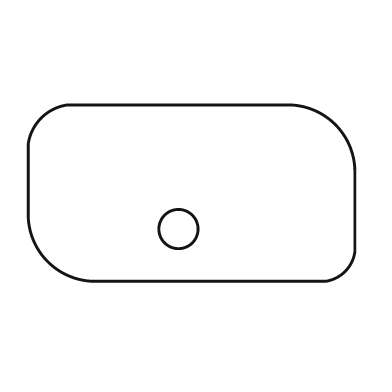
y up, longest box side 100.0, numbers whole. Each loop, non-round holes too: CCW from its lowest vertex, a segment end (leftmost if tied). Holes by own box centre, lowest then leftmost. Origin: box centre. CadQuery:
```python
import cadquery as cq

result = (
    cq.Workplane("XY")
    .moveTo(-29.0, -27.0)
    .lineTo(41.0, -27.0)
    .threePointArc((47.0, -24.0), (50.0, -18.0))
    .lineTo(50.0, 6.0)
    .threePointArc((44.0, 21.0), (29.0, 27.0))
    .lineTo(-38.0, 27.0)
    .threePointArc((-46.0, 23.0), (-50.0, 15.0))
    .lineTo(-50.0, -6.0)
    .threePointArc((-44.0, -21.0), (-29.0, -27.0))
    .close()
    .moveTo(-4.0, -11.0)
    .circle(6.0)
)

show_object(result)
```